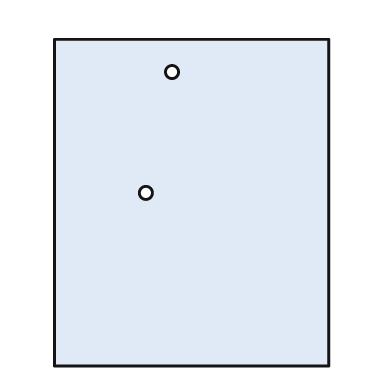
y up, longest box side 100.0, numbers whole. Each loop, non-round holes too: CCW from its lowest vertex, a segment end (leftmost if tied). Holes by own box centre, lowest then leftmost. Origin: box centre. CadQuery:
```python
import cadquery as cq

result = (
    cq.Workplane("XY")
    .moveTo(-42.0, -50.0)
    .lineTo(42.0, -50.0)
    .lineTo(42.0, 50.0)
    .lineTo(-42.0, 50.0)
    .close()
    .moveTo(-14.0, 3.0)
    .circle(2.0)
    .moveTo(-6.0, 40.0)
    .circle(2.0)
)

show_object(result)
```